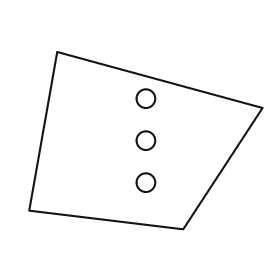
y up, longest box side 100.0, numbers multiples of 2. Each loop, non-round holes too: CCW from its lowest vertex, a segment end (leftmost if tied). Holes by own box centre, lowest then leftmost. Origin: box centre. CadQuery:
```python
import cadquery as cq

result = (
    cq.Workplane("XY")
    .moveTo(16.0, -38.0)
    .lineTo(50.0, 14.0)
    .lineTo(-38.0, 38.0)
    .lineTo(-50.0, -30.0)
    .close()
    .moveTo(0.0, -18.0)
    .circle(4.0)
    .moveTo(0.0, 0.0)
    .circle(4.0)
    .moveTo(0.0, 18.0)
    .circle(4.0)
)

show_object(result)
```